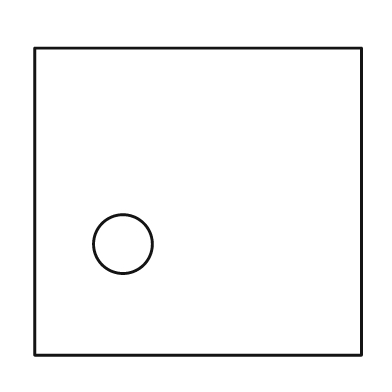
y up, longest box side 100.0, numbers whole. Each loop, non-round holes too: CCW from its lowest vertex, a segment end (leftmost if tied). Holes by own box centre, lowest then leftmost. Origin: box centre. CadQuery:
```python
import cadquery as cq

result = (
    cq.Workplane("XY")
    .moveTo(-50.0, -47.0)
    .lineTo(50.0, -47.0)
    .lineTo(50.0, 47.0)
    .lineTo(-50.0, 47.0)
    .close()
    .moveTo(-23.0, -13.0)
    .circle(9.0)
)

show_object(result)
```